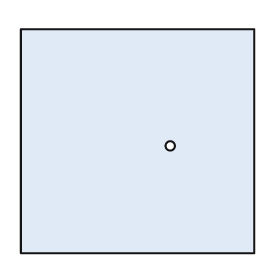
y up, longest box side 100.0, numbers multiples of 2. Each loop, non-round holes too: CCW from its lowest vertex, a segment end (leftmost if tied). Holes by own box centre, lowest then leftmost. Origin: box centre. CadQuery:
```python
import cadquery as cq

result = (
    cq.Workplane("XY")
    .moveTo(-50.0, -48.0)
    .lineTo(50.0, -48.0)
    .lineTo(50.0, 48.0)
    .lineTo(-50.0, 48.0)
    .close()
    .moveTo(14.0, -2.0)
    .circle(2.0)
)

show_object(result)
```